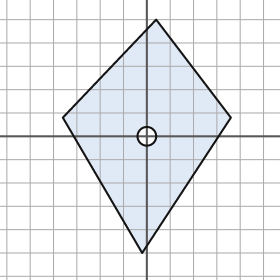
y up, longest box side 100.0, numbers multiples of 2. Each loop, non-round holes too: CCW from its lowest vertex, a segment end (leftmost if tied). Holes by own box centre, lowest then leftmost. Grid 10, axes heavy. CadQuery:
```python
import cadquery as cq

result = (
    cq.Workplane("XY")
    .moveTo(-2.0, -50.0)
    .lineTo(36.0, 8.0)
    .lineTo(4.0, 50.0)
    .lineTo(-36.0, 8.0)
    .close()
    .moveTo(0.0, 0.0)
    .circle(4.0)
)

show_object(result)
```